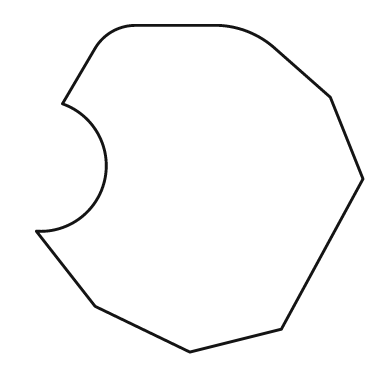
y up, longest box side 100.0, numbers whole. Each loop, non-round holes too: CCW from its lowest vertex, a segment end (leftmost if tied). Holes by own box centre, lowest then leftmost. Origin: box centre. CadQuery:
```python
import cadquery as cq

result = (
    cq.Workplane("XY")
    .moveTo(-3.0, -50.0)
    .lineTo(25.0, -43.0)
    .lineTo(50.0, 3.0)
    .lineTo(40.0, 28.0)
    .lineTo(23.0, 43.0)
    .threePointArc((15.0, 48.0), (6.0, 50.0))
    .lineTo(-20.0, 50.0)
    .threePointArc((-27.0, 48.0), (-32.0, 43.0))
    .lineTo(-42.0, 26.0)
    .threePointArc((-29.0, 3.0), (-50.0, -13.0))
    .lineTo(-32.0, -36.0)
    .close()
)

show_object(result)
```